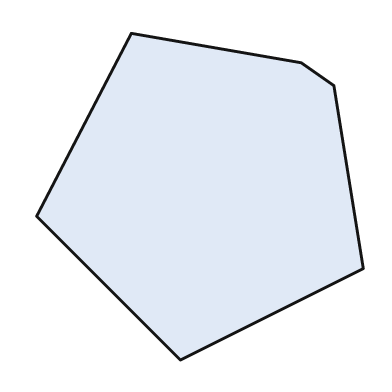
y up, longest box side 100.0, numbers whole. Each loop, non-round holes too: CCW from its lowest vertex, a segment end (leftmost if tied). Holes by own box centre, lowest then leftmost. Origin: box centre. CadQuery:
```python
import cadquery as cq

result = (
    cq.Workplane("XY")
    .moveTo(-6.0, -50.0)
    .lineTo(50.0, -22.0)
    .lineTo(41.0, 34.0)
    .lineTo(31.0, 41.0)
    .lineTo(-21.0, 50.0)
    .lineTo(-50.0, -6.0)
    .close()
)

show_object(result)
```